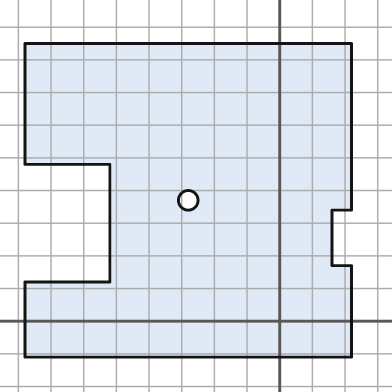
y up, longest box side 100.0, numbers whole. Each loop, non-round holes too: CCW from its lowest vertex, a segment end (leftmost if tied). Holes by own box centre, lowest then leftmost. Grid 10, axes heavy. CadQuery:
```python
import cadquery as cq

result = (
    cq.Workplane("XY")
    .moveTo(-78.0, -11.0)
    .lineTo(22.0, -11.0)
    .lineTo(22.0, 17.0)
    .lineTo(16.0, 17.0)
    .lineTo(16.0, 34.0)
    .lineTo(22.0, 34.0)
    .lineTo(22.0, 85.0)
    .lineTo(-78.0, 85.0)
    .lineTo(-78.0, 48.0)
    .lineTo(-52.0, 48.0)
    .lineTo(-52.0, 12.0)
    .lineTo(-78.0, 12.0)
    .close()
    .moveTo(-28.0, 37.0)
    .circle(3.0)
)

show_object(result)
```